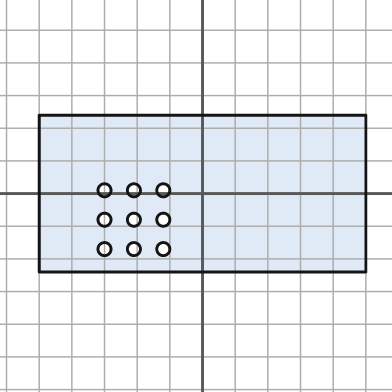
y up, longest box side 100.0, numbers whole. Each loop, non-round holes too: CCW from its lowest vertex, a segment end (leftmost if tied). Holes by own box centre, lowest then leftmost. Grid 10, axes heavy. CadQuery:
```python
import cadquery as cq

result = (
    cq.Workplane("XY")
    .moveTo(-50.0, -24.0)
    .lineTo(50.0, -24.0)
    .lineTo(50.0, 24.0)
    .lineTo(-50.0, 24.0)
    .close()
    .moveTo(-30.0, -17.0)
    .circle(2.0)
    .moveTo(-21.0, -17.0)
    .circle(2.0)
    .moveTo(-12.0, -17.0)
    .circle(2.0)
    .moveTo(-30.0, -8.0)
    .circle(2.0)
    .moveTo(-21.0, -8.0)
    .circle(2.0)
    .moveTo(-12.0, -8.0)
    .circle(2.0)
    .moveTo(-30.0, 1.0)
    .circle(2.0)
    .moveTo(-21.0, 1.0)
    .circle(2.0)
    .moveTo(-12.0, 1.0)
    .circle(2.0)
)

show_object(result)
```